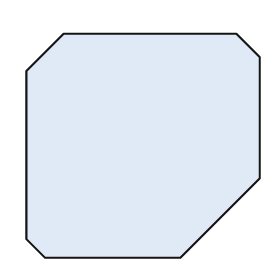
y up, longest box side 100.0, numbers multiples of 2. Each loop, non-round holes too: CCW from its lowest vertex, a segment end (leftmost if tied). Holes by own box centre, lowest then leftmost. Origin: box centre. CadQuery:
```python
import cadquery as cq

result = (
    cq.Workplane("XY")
    .moveTo(-42.0, -48.0)
    .lineTo(16.0, -48.0)
    .lineTo(50.0, -14.0)
    .lineTo(50.0, 38.0)
    .lineTo(40.0, 48.0)
    .lineTo(-34.0, 48.0)
    .lineTo(-50.0, 32.0)
    .lineTo(-50.0, -40.0)
    .close()
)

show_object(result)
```